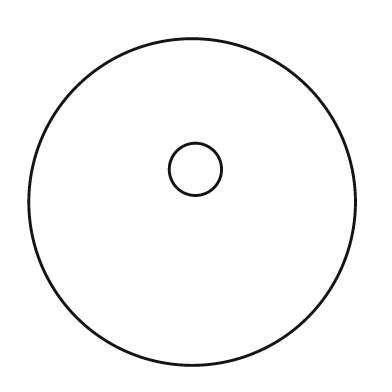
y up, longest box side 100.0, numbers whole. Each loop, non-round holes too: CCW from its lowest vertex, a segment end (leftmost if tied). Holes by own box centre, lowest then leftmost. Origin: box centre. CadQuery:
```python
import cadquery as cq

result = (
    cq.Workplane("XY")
    .moveTo(0.0, 0.0)
    .circle(50.0)
    .moveTo(1.0, 10.0)
    .circle(8.0)
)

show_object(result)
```